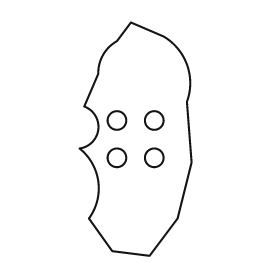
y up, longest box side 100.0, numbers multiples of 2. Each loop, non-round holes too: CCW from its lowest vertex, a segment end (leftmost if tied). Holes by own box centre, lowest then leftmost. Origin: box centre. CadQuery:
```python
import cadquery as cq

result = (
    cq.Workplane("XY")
    .moveTo(6.0, -50.0)
    .lineTo(18.0, -34.0)
    .lineTo(24.0, -10.0)
    .lineTo(22.0, 16.0)
    .threePointArc((22.0, 32.0), (12.0, 44.0))
    .lineTo(-2.0, 50.0)
    .lineTo(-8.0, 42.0)
    .threePointArc((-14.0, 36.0), (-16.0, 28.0))
    .lineTo(-22.0, 14.0)
    .threePointArc((-16.0, 4.0), (-24.0, -4.0))
    .threePointArc((-16.0, -18.0), (-20.0, -34.0))
    .lineTo(-10.0, -48.0)
    .close()
    .moveTo(-8.0, -8.0)
    .circle(4.0)
    .moveTo(8.0, -8.0)
    .circle(4.0)
    .moveTo(-8.0, 8.0)
    .circle(4.0)
    .moveTo(8.0, 8.0)
    .circle(4.0)
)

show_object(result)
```